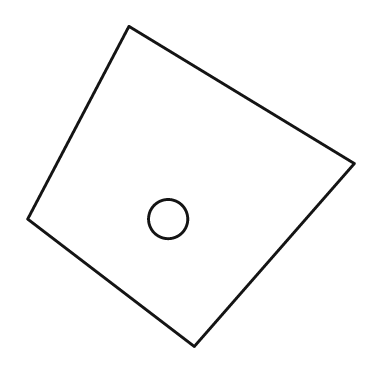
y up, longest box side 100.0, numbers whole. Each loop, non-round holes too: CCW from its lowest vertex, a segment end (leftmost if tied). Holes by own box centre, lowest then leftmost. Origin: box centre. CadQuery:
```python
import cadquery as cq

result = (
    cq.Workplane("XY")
    .moveTo(1.0, -49.0)
    .lineTo(50.0, 7.0)
    .lineTo(-19.0, 49.0)
    .lineTo(-50.0, -10.0)
    .close()
    .moveTo(-7.0, -10.0)
    .circle(6.0)
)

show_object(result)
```